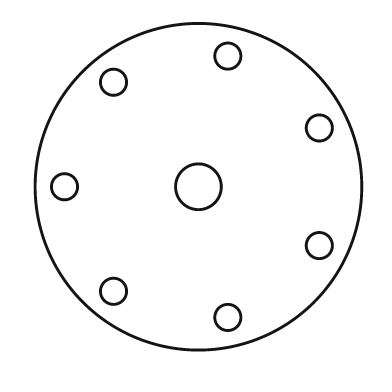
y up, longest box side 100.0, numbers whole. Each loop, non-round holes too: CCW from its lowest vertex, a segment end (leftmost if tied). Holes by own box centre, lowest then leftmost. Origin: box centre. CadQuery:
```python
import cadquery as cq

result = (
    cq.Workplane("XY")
    .moveTo(0.0, 0.0)
    .circle(50.0)
    .moveTo(9.0, -40.0)
    .circle(4.0)
    .moveTo(-26.0, -32.0)
    .circle(4.0)
    .moveTo(37.0, -18.0)
    .circle(4.0)
    .moveTo(-41.0, 0.0)
    .circle(4.0)
    .moveTo(0.0, 0.0)
    .circle(7.0)
    .moveTo(37.0, 18.0)
    .circle(4.0)
    .moveTo(-26.0, 32.0)
    .circle(4.0)
    .moveTo(9.0, 40.0)
    .circle(4.0)
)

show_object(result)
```